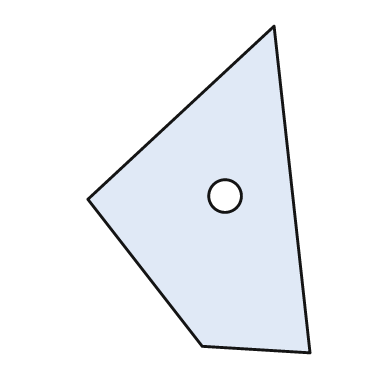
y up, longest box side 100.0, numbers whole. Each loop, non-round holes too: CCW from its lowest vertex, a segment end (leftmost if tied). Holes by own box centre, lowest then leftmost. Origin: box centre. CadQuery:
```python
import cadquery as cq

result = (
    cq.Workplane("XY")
    .moveTo(34.0, -50.0)
    .lineTo(23.0, 50.0)
    .lineTo(-34.0, -3.0)
    .lineTo(1.0, -48.0)
    .close()
    .moveTo(8.0, -2.0)
    .circle(5.0)
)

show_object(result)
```